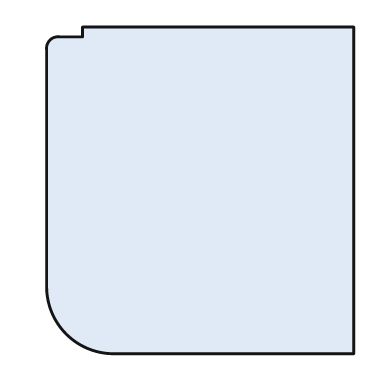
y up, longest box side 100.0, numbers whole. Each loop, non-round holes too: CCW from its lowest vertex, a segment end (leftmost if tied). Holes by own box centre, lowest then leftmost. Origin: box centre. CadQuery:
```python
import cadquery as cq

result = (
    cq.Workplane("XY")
    .moveTo(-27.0, -50.0)
    .lineTo(47.0, -50.0)
    .lineTo(47.0, 50.0)
    .lineTo(-36.0, 50.0)
    .lineTo(-36.0, 47.0)
    .lineTo(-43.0, 47.0)
    .threePointArc((-46.0, 46.0), (-47.0, 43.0))
    .lineTo(-47.0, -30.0)
    .threePointArc((-41.0, -44.0), (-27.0, -50.0))
    .close()
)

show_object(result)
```